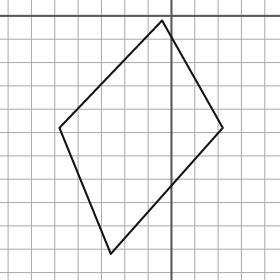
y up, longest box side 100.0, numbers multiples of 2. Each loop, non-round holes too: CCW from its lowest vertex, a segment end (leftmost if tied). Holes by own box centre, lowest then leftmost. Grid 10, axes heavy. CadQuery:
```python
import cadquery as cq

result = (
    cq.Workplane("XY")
    .moveTo(-26.0, -102.0)
    .lineTo(22.0, -48.0)
    .lineTo(-4.0, -2.0)
    .lineTo(-48.0, -48.0)
    .close()
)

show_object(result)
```